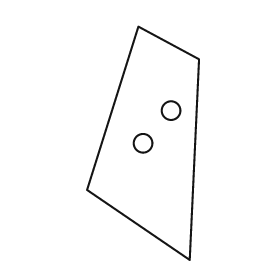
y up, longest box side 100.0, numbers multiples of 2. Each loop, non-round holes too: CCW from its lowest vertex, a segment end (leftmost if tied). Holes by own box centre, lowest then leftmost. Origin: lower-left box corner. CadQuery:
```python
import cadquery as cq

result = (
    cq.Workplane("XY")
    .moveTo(44.0, 0.0)
    .lineTo(48.0, 86.0)
    .lineTo(22.0, 100.0)
    .lineTo(0.0, 30.0)
    .close()
    .moveTo(24.0, 50.0)
    .circle(4.0)
    .moveTo(36.0, 64.0)
    .circle(4.0)
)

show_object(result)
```